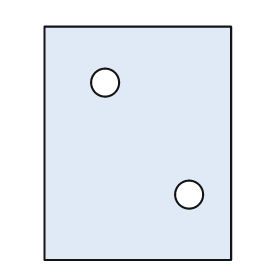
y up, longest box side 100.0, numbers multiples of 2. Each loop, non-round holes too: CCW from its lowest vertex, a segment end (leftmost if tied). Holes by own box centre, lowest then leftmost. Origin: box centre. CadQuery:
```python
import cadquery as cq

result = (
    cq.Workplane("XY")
    .moveTo(-40.0, -50.0)
    .lineTo(40.0, -50.0)
    .lineTo(40.0, 50.0)
    .lineTo(-40.0, 50.0)
    .close()
    .moveTo(22.0, -22.0)
    .circle(6.0)
    .moveTo(-14.0, 26.0)
    .circle(6.0)
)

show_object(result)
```